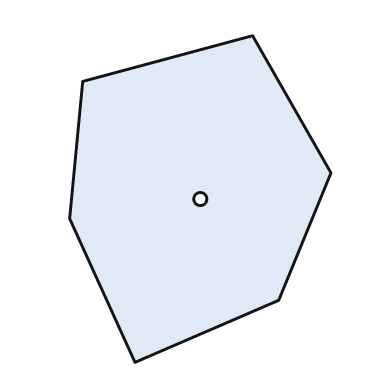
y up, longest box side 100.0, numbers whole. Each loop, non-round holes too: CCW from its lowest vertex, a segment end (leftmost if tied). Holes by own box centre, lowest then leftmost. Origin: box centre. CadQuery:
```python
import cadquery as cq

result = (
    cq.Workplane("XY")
    .moveTo(-20.0, -50.0)
    .lineTo(24.0, -31.0)
    .lineTo(40.0, 8.0)
    .lineTo(16.0, 50.0)
    .lineTo(-36.0, 36.0)
    .lineTo(-40.0, -6.0)
    .close()
    .moveTo(0.0, 0.0)
    .circle(2.0)
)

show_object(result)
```